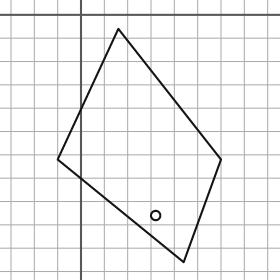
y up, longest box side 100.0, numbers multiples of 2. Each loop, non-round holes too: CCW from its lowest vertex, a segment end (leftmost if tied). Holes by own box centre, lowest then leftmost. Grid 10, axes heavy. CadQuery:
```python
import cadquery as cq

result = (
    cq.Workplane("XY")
    .moveTo(44.0, -106.0)
    .lineTo(60.0, -62.0)
    .lineTo(16.0, -6.0)
    .lineTo(-10.0, -62.0)
    .close()
    .moveTo(32.0, -86.0)
    .circle(2.0)
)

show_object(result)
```